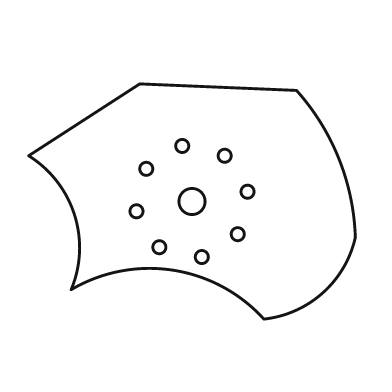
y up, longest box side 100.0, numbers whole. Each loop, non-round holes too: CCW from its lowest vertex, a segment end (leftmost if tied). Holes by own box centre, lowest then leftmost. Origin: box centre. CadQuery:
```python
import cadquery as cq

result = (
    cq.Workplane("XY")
    .moveTo(22.0, -36.0)
    .threePointArc((40.0, -28.0), (50.0, -11.0))
    .threePointArc((45.0, 13.0), (32.0, 34.0))
    .lineTo(-16.0, 36.0)
    .lineTo(-50.0, 14.0)
    .threePointArc((-36.0, -4.0), (-37.0, -27.0))
    .threePointArc((-6.0, -21.0), (22.0, -36.0))
    .close()
    .moveTo(3.0, -17.0)
    .circle(2.0)
    .moveTo(-10.0, -14.0)
    .circle(2.0)
    .moveTo(14.0, -10.0)
    .circle(2.0)
    .moveTo(-17.0, -3.0)
    .circle(2.0)
    .moveTo(0.0, 0.0)
    .circle(4.0)
    .moveTo(17.0, 3.0)
    .circle(2.0)
    .moveTo(-14.0, 10.0)
    .circle(2.0)
    .moveTo(10.0, 14.0)
    .circle(2.0)
    .moveTo(-3.0, 17.0)
    .circle(2.0)
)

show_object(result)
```